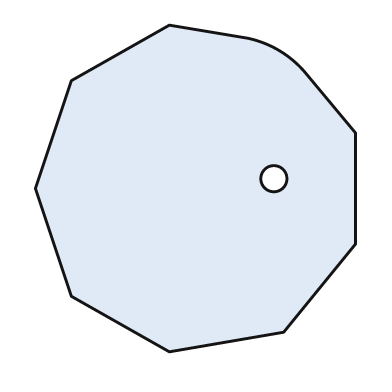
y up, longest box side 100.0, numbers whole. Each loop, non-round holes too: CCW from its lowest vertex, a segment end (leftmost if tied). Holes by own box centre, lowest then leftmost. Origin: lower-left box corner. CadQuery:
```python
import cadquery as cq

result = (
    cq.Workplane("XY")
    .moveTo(41.0, 0.0)
    .lineTo(76.0, 6.0)
    .lineTo(98.0, 33.0)
    .lineTo(98.0, 67.0)
    .lineTo(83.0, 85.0)
    .threePointArc((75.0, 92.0), (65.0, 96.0))
    .lineTo(41.0, 100.0)
    .lineTo(11.0, 83.0)
    .lineTo(0.0, 50.0)
    .lineTo(11.0, 17.0)
    .close()
    .moveTo(73.0, 53.0)
    .circle(4.0)
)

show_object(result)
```